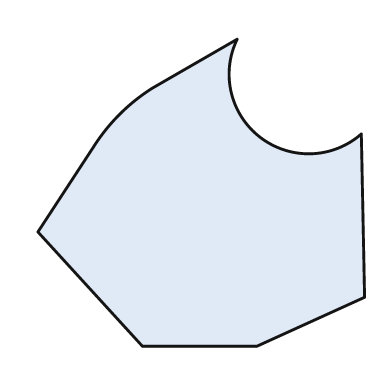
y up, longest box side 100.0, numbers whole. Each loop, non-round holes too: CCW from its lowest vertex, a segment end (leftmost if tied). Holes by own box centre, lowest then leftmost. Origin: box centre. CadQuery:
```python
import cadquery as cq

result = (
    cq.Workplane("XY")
    .moveTo(-18.0, -47.0)
    .lineTo(17.0, -47.0)
    .lineTo(50.0, -32.0)
    .lineTo(49.0, 18.0)
    .threePointArc((18.0, 17.0), (11.0, 47.0))
    .lineTo(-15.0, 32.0)
    .threePointArc((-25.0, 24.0), (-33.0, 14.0))
    .lineTo(-50.0, -12.0)
    .close()
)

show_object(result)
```